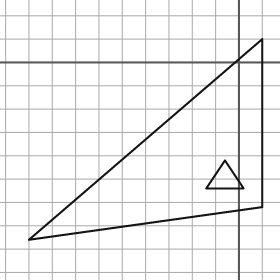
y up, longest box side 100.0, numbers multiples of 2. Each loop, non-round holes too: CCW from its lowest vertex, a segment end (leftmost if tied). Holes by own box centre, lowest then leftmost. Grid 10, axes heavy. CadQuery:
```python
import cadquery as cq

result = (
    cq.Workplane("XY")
    .moveTo(-90.0, -76.0)
    .lineTo(10.0, -62.0)
    .lineTo(10.0, 10.0)
    .close()
    .moveTo(-14.0, -54.0)
    .lineTo(2.0, -54.0)
    .lineTo(-6.0, -42.0)
    .close()
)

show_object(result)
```